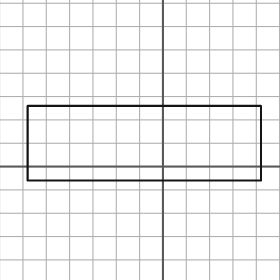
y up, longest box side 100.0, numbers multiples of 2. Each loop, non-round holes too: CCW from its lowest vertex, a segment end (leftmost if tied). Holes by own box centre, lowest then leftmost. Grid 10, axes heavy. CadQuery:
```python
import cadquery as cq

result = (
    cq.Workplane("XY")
    .moveTo(-58.0, -6.0)
    .lineTo(42.0, -6.0)
    .lineTo(42.0, 26.0)
    .lineTo(-58.0, 26.0)
    .close()
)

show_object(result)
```